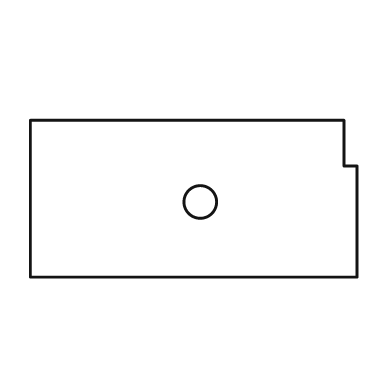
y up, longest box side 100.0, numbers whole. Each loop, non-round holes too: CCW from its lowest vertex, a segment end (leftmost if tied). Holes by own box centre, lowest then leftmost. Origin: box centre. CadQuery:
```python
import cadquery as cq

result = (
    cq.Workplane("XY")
    .moveTo(-50.0, -24.0)
    .lineTo(50.0, -24.0)
    .lineTo(50.0, 10.0)
    .lineTo(46.0, 10.0)
    .lineTo(46.0, 24.0)
    .lineTo(-50.0, 24.0)
    .close()
    .moveTo(2.0, -1.0)
    .circle(5.0)
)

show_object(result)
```